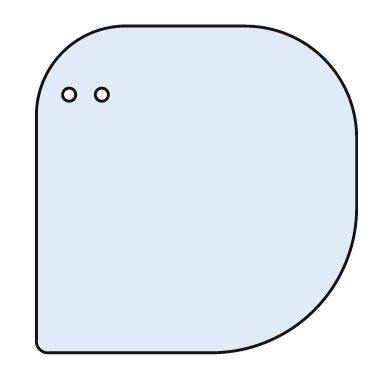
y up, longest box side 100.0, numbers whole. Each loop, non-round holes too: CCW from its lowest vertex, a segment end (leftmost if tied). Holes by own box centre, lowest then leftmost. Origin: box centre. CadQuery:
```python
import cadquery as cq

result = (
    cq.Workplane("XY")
    .moveTo(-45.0, -50.0)
    .lineTo(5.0, -50.0)
    .threePointArc((36.0, -37.0), (49.0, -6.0))
    .lineTo(49.0, 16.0)
    .threePointArc((39.0, 40.0), (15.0, 50.0))
    .lineTo(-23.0, 50.0)
    .threePointArc((-41.0, 42.0), (-49.0, 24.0))
    .lineTo(-49.0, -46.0)
    .threePointArc((-48.0, -49.0), (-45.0, -50.0))
    .close()
    .moveTo(-39.0, 29.0)
    .circle(2.0)
    .moveTo(-29.0, 29.0)
    .circle(2.0)
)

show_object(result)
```